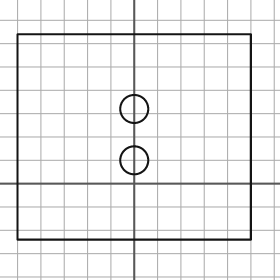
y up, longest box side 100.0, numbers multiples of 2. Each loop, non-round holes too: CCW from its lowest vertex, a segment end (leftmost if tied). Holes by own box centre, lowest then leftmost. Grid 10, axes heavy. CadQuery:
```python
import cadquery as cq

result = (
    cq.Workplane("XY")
    .moveTo(-50.0, -24.0)
    .lineTo(50.0, -24.0)
    .lineTo(50.0, 64.0)
    .lineTo(-50.0, 64.0)
    .close()
    .moveTo(0.0, 10.0)
    .circle(6.0)
    .moveTo(0.0, 32.0)
    .circle(6.0)
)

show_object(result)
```